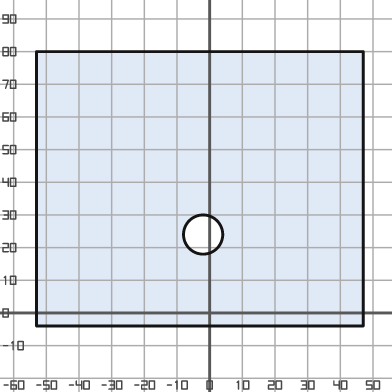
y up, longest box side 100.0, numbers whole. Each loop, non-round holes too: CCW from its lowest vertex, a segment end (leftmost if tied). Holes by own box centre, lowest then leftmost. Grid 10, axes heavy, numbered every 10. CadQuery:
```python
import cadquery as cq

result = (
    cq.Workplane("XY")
    .moveTo(-53.0, -4.0)
    .lineTo(47.0, -4.0)
    .lineTo(47.0, 80.0)
    .lineTo(-53.0, 80.0)
    .close()
    .moveTo(-2.0, 24.0)
    .circle(6.0)
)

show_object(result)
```